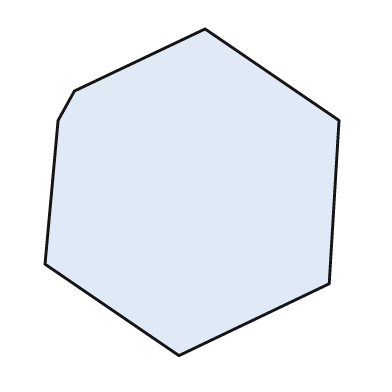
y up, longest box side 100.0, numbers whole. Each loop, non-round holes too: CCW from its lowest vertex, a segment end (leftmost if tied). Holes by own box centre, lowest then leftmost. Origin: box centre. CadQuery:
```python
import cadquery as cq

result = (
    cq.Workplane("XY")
    .moveTo(-4.0, -50.0)
    .lineTo(42.0, -28.0)
    .lineTo(45.0, 22.0)
    .lineTo(4.0, 50.0)
    .lineTo(-36.0, 31.0)
    .lineTo(-41.0, 22.0)
    .lineTo(-45.0, -22.0)
    .close()
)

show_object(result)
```